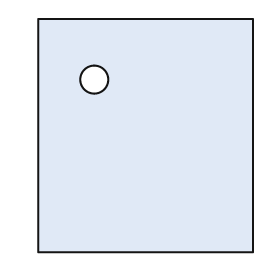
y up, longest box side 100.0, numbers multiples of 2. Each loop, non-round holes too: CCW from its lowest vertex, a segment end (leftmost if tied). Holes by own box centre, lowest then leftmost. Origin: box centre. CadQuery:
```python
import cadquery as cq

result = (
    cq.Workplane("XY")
    .moveTo(-46.0, -50.0)
    .lineTo(46.0, -50.0)
    .lineTo(46.0, 50.0)
    .lineTo(-46.0, 50.0)
    .close()
    .moveTo(-22.0, 24.0)
    .circle(6.0)
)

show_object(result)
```